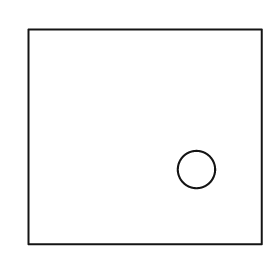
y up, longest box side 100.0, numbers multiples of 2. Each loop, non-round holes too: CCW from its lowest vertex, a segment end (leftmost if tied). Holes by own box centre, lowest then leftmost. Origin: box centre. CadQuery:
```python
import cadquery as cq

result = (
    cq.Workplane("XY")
    .moveTo(-50.0, -46.0)
    .lineTo(50.0, -46.0)
    .lineTo(50.0, 46.0)
    .lineTo(-50.0, 46.0)
    .close()
    .moveTo(22.0, -14.0)
    .circle(8.0)
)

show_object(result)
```